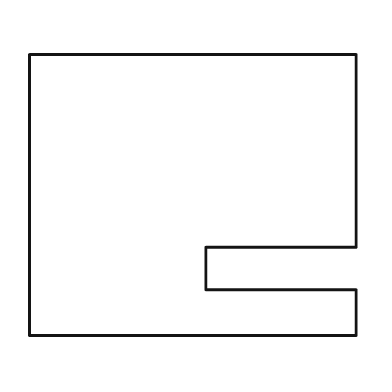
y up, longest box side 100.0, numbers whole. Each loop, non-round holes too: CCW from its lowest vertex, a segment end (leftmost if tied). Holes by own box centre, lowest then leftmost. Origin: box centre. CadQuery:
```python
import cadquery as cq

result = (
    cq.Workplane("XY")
    .moveTo(-50.0, -43.0)
    .lineTo(50.0, -43.0)
    .lineTo(50.0, -29.0)
    .lineTo(4.0, -29.0)
    .lineTo(4.0, -16.0)
    .lineTo(50.0, -16.0)
    .lineTo(50.0, 43.0)
    .lineTo(-50.0, 43.0)
    .close()
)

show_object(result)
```